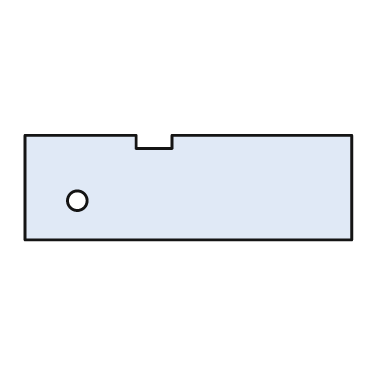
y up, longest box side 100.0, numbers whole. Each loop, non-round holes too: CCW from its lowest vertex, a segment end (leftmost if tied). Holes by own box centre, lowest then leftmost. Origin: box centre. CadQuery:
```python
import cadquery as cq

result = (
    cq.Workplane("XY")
    .moveTo(-50.0, -16.0)
    .lineTo(50.0, -16.0)
    .lineTo(50.0, 16.0)
    .lineTo(-5.0, 16.0)
    .lineTo(-5.0, 12.0)
    .lineTo(-16.0, 12.0)
    .lineTo(-16.0, 16.0)
    .lineTo(-50.0, 16.0)
    .close()
    .moveTo(-34.0, -4.0)
    .circle(3.0)
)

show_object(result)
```